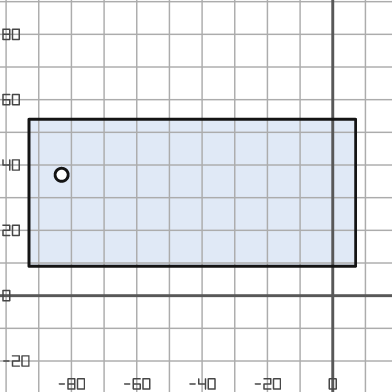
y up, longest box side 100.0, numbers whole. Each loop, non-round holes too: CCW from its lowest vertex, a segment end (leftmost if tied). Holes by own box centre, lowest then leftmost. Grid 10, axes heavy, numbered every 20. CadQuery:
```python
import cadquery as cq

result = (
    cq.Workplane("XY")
    .moveTo(-93.0, 9.0)
    .lineTo(7.0, 9.0)
    .lineTo(7.0, 54.0)
    .lineTo(-93.0, 54.0)
    .close()
    .moveTo(-83.0, 37.0)
    .circle(2.0)
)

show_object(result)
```